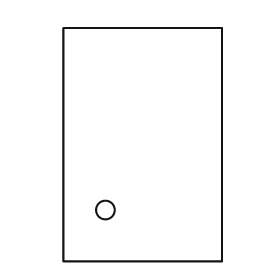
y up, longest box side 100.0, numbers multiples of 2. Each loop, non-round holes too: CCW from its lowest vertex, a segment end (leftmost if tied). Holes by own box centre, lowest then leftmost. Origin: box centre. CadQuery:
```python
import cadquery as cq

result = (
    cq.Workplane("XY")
    .moveTo(-34.0, -50.0)
    .lineTo(34.0, -50.0)
    .lineTo(34.0, 50.0)
    .lineTo(-34.0, 50.0)
    .close()
    .moveTo(-16.0, -28.0)
    .circle(4.0)
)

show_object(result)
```